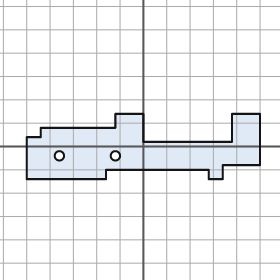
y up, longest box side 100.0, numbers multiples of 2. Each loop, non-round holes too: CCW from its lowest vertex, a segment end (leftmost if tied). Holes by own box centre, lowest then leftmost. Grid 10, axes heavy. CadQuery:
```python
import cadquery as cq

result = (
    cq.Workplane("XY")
    .moveTo(-50.0, -14.0)
    .lineTo(-16.0, -14.0)
    .lineTo(-16.0, -10.0)
    .lineTo(28.0, -10.0)
    .lineTo(28.0, -14.0)
    .lineTo(34.0, -14.0)
    .lineTo(34.0, -8.0)
    .lineTo(50.0, -8.0)
    .lineTo(50.0, 14.0)
    .lineTo(38.0, 14.0)
    .lineTo(38.0, 2.0)
    .lineTo(0.0, 2.0)
    .lineTo(0.0, 14.0)
    .lineTo(-12.0, 14.0)
    .lineTo(-12.0, 8.0)
    .lineTo(-44.0, 8.0)
    .lineTo(-44.0, 4.0)
    .lineTo(-50.0, 4.0)
    .close()
    .moveTo(-36.0, -4.0)
    .circle(2.0)
    .moveTo(-12.0, -4.0)
    .circle(2.0)
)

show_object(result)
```